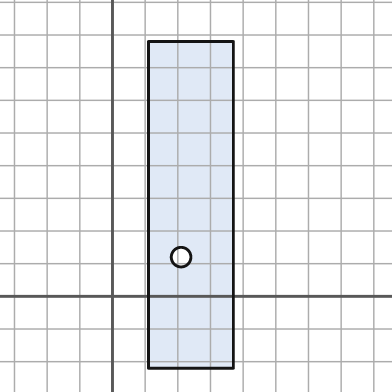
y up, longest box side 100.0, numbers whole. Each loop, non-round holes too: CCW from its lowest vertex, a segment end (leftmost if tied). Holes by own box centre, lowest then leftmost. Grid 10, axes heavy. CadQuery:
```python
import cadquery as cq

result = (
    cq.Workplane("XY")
    .moveTo(11.0, -22.0)
    .lineTo(37.0, -22.0)
    .lineTo(37.0, 78.0)
    .lineTo(11.0, 78.0)
    .close()
    .moveTo(21.0, 12.0)
    .circle(3.0)
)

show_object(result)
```